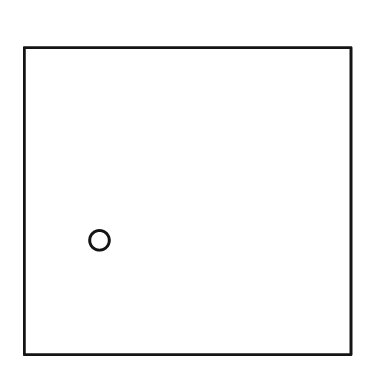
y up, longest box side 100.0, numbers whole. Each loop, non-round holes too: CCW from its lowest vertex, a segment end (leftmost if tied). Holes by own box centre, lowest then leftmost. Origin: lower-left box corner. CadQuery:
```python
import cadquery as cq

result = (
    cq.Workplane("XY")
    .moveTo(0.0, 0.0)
    .lineTo(100.0, 0.0)
    .lineTo(100.0, 94.0)
    .lineTo(0.0, 94.0)
    .close()
    .moveTo(23.0, 35.0)
    .circle(3.0)
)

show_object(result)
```